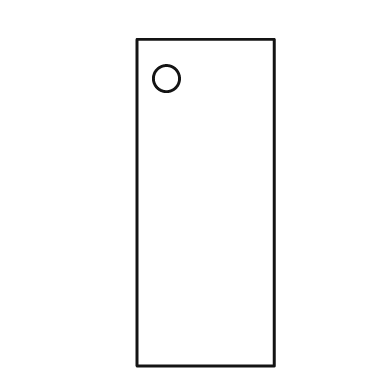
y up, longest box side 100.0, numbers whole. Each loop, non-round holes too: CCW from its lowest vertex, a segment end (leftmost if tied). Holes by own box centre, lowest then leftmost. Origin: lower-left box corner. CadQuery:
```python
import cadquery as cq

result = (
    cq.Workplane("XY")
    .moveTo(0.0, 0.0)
    .lineTo(42.0, 0.0)
    .lineTo(42.0, 100.0)
    .lineTo(0.0, 100.0)
    .close()
    .moveTo(9.0, 88.0)
    .circle(4.0)
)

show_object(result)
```